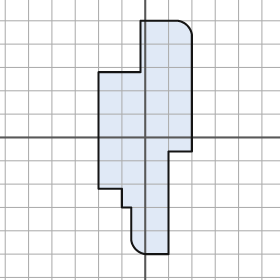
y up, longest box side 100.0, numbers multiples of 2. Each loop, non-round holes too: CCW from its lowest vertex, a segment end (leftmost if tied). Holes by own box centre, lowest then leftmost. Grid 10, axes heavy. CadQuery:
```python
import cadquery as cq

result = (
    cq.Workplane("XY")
    .moveTo(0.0, -50.0)
    .lineTo(10.0, -50.0)
    .lineTo(10.0, -6.0)
    .lineTo(20.0, -6.0)
    .lineTo(20.0, 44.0)
    .threePointArc((18.0, 48.0), (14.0, 50.0))
    .lineTo(-2.0, 50.0)
    .lineTo(-2.0, 28.0)
    .lineTo(-20.0, 28.0)
    .lineTo(-20.0, -22.0)
    .lineTo(-10.0, -22.0)
    .lineTo(-10.0, -30.0)
    .lineTo(-6.0, -30.0)
    .lineTo(-6.0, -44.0)
    .threePointArc((-4.0, -48.0), (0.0, -50.0))
    .close()
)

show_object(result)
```